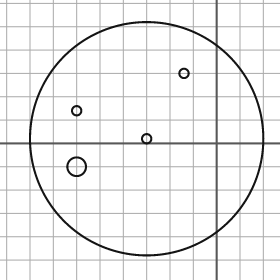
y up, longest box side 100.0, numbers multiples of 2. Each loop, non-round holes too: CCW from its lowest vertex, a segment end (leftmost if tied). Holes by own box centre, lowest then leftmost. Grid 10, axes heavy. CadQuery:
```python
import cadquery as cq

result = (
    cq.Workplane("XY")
    .moveTo(-30.0, 2.0)
    .circle(50.0)
    .moveTo(-60.0, -10.0)
    .circle(4.0)
    .moveTo(-30.0, 2.0)
    .circle(2.0)
    .moveTo(-60.0, 14.0)
    .circle(2.0)
    .moveTo(-14.0, 30.0)
    .circle(2.0)
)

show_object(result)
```